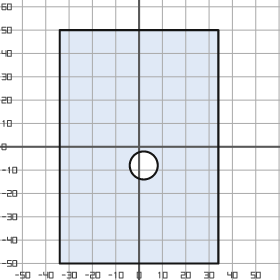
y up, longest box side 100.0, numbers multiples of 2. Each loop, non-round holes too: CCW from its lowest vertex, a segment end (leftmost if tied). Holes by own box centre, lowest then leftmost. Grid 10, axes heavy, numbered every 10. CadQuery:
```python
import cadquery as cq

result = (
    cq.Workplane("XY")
    .moveTo(-34.0, -50.0)
    .lineTo(34.0, -50.0)
    .lineTo(34.0, 50.0)
    .lineTo(-34.0, 50.0)
    .close()
    .moveTo(2.0, -8.0)
    .circle(6.0)
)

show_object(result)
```